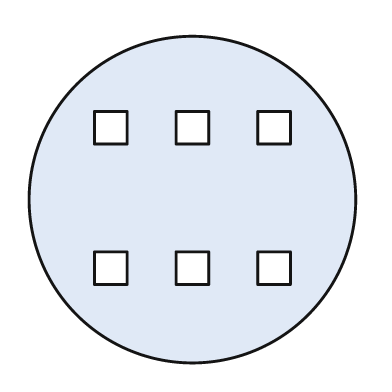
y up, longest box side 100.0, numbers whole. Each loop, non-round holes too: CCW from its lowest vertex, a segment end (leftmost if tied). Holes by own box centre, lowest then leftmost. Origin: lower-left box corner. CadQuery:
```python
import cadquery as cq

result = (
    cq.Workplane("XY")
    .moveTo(50.0, 50.0)
    .circle(50.0)
    .moveTo(20.0, 24.0)
    .lineTo(30.0, 24.0)
    .lineTo(30.0, 34.0)
    .lineTo(20.0, 34.0)
    .close()
    .moveTo(45.0, 24.0)
    .lineTo(55.0, 24.0)
    .lineTo(55.0, 34.0)
    .lineTo(45.0, 34.0)
    .close()
    .moveTo(70.0, 24.0)
    .lineTo(80.0, 24.0)
    .lineTo(80.0, 34.0)
    .lineTo(70.0, 34.0)
    .close()
    .moveTo(20.0, 67.0)
    .lineTo(30.0, 67.0)
    .lineTo(30.0, 77.0)
    .lineTo(20.0, 77.0)
    .close()
    .moveTo(45.0, 67.0)
    .lineTo(55.0, 67.0)
    .lineTo(55.0, 77.0)
    .lineTo(45.0, 77.0)
    .close()
    .moveTo(70.0, 67.0)
    .lineTo(80.0, 67.0)
    .lineTo(80.0, 77.0)
    .lineTo(70.0, 77.0)
    .close()
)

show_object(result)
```